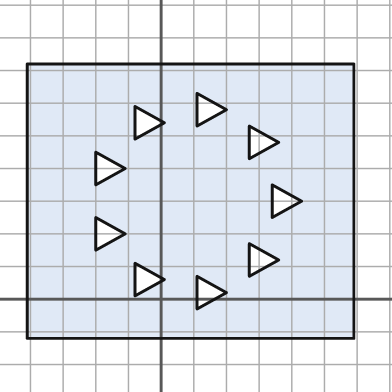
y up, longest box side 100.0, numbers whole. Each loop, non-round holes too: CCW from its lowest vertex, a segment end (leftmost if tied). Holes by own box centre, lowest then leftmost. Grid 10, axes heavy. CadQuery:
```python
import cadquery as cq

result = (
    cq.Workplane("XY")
    .moveTo(-41.0, -12.0)
    .lineTo(59.0, -12.0)
    .lineTo(59.0, 72.0)
    .lineTo(-41.0, 72.0)
    .close()
    .moveTo(11.0, -3.0)
    .lineTo(20.0, 2.0)
    .lineTo(11.0, 7.0)
    .close()
    .moveTo(-8.0, 1.0)
    .lineTo(1.0, 6.0)
    .lineTo(-8.0, 11.0)
    .close()
    .moveTo(27.0, 7.0)
    .lineTo(36.0, 12.0)
    .lineTo(27.0, 17.0)
    .close()
    .moveTo(-20.0, 15.0)
    .lineTo(-11.0, 20.0)
    .lineTo(-20.0, 25.0)
    .close()
    .moveTo(34.0, 25.0)
    .lineTo(43.0, 30.0)
    .lineTo(34.0, 35.0)
    .close()
    .moveTo(-20.0, 35.0)
    .lineTo(-11.0, 40.0)
    .lineTo(-20.0, 45.0)
    .close()
    .moveTo(27.0, 43.0)
    .lineTo(36.0, 48.0)
    .lineTo(27.0, 53.0)
    .close()
    .moveTo(-8.0, 49.0)
    .lineTo(1.0, 54.0)
    .lineTo(-8.0, 59.0)
    .close()
    .moveTo(11.0, 53.0)
    .lineTo(20.0, 58.0)
    .lineTo(11.0, 63.0)
    .close()
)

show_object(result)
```